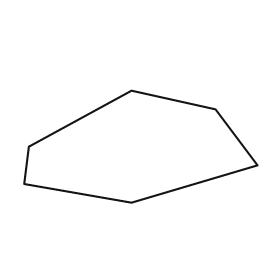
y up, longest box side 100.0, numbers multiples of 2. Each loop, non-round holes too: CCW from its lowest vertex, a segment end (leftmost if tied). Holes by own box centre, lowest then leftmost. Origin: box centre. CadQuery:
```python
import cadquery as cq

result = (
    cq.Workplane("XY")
    .moveTo(-4.0, -24.0)
    .lineTo(50.0, -8.0)
    .lineTo(32.0, 16.0)
    .lineTo(-4.0, 24.0)
    .lineTo(-48.0, 0.0)
    .lineTo(-50.0, -16.0)
    .close()
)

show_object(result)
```